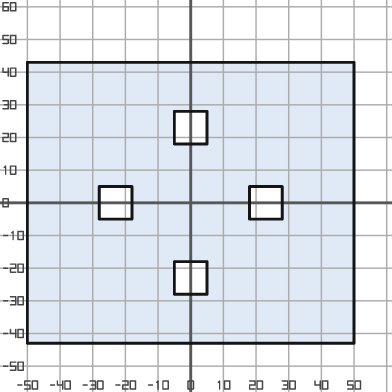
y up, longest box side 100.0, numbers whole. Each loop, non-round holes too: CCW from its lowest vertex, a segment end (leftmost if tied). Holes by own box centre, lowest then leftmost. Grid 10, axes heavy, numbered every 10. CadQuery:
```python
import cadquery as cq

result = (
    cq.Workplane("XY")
    .moveTo(-50.0, -43.0)
    .lineTo(50.0, -43.0)
    .lineTo(50.0, 43.0)
    .lineTo(-50.0, 43.0)
    .close()
    .moveTo(-5.0, -28.0)
    .lineTo(5.0, -28.0)
    .lineTo(5.0, -18.0)
    .lineTo(-5.0, -18.0)
    .close()
    .moveTo(-28.0, -5.0)
    .lineTo(-18.0, -5.0)
    .lineTo(-18.0, 5.0)
    .lineTo(-28.0, 5.0)
    .close()
    .moveTo(18.0, -5.0)
    .lineTo(28.0, -5.0)
    .lineTo(28.0, 5.0)
    .lineTo(18.0, 5.0)
    .close()
    .moveTo(-5.0, 18.0)
    .lineTo(5.0, 18.0)
    .lineTo(5.0, 28.0)
    .lineTo(-5.0, 28.0)
    .close()
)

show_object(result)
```